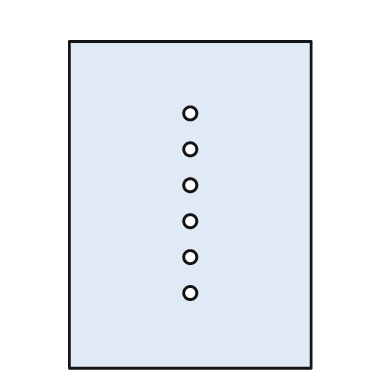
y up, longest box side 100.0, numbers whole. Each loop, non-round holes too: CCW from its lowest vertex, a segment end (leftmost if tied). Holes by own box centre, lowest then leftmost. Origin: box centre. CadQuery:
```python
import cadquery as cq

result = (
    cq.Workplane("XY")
    .moveTo(-37.0, -50.0)
    .lineTo(37.0, -50.0)
    .lineTo(37.0, 50.0)
    .lineTo(-37.0, 50.0)
    .close()
    .moveTo(0.0, -27.0)
    .circle(2.0)
    .moveTo(0.0, -16.0)
    .circle(2.0)
    .moveTo(0.0, -5.0)
    .circle(2.0)
    .moveTo(0.0, 6.0)
    .circle(2.0)
    .moveTo(0.0, 17.0)
    .circle(2.0)
    .moveTo(0.0, 28.0)
    .circle(2.0)
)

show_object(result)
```